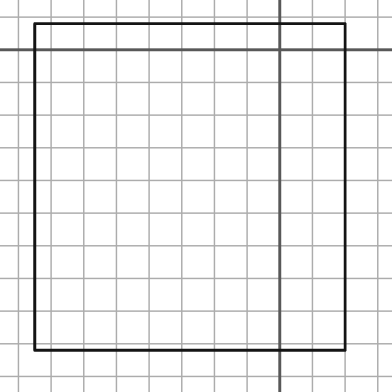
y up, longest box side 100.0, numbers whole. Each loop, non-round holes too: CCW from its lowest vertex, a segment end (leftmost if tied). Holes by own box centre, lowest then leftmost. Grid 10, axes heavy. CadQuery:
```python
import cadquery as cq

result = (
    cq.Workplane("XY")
    .moveTo(-75.0, -92.0)
    .lineTo(20.0, -92.0)
    .lineTo(20.0, 8.0)
    .lineTo(-75.0, 8.0)
    .close()
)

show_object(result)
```